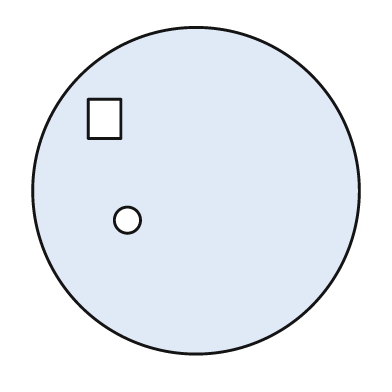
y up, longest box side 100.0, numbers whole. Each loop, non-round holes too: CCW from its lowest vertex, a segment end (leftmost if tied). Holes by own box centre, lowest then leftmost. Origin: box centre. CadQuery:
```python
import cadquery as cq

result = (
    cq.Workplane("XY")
    .moveTo(0.0, 0.0)
    .circle(50.0)
    .moveTo(-21.0, -9.0)
    .circle(4.0)
    .moveTo(-33.0, 16.0)
    .lineTo(-23.0, 16.0)
    .lineTo(-23.0, 28.0)
    .lineTo(-33.0, 28.0)
    .close()
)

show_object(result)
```